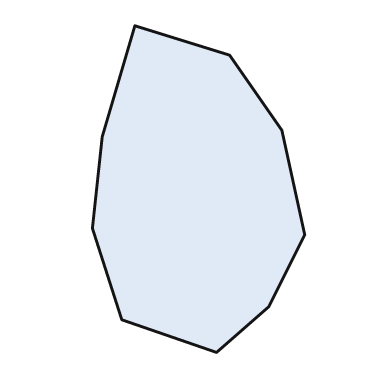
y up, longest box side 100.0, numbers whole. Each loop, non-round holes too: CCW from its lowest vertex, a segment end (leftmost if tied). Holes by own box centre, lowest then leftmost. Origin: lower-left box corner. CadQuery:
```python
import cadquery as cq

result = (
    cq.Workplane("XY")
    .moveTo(38.0, 0.0)
    .lineTo(54.0, 14.0)
    .lineTo(65.0, 36.0)
    .lineTo(58.0, 68.0)
    .lineTo(42.0, 91.0)
    .lineTo(13.0, 100.0)
    .lineTo(3.0, 66.0)
    .lineTo(0.0, 38.0)
    .lineTo(9.0, 10.0)
    .close()
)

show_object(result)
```